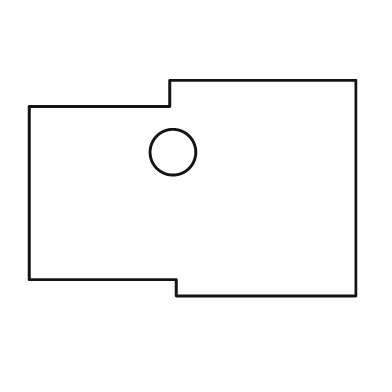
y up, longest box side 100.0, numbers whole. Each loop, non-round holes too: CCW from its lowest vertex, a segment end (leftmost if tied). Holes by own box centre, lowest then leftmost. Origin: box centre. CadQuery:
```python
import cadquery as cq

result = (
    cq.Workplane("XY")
    .moveTo(-5.0, -33.0)
    .lineTo(50.0, -33.0)
    .lineTo(50.0, 33.0)
    .lineTo(-7.0, 33.0)
    .lineTo(-7.0, 25.0)
    .lineTo(-50.0, 25.0)
    .lineTo(-50.0, -28.0)
    .lineTo(-5.0, -28.0)
    .close()
    .moveTo(-6.0, 11.0)
    .circle(7.0)
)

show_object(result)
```